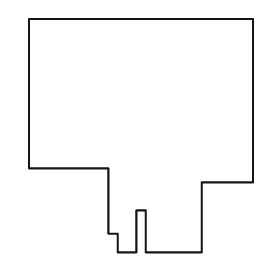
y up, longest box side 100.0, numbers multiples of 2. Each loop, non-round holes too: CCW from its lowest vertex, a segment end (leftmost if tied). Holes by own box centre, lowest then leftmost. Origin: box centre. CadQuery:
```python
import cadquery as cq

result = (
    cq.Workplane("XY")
    .moveTo(-10.0, -50.0)
    .lineTo(-2.0, -50.0)
    .lineTo(-2.0, -32.0)
    .lineTo(2.0, -32.0)
    .lineTo(2.0, -50.0)
    .lineTo(26.0, -50.0)
    .lineTo(26.0, -20.0)
    .lineTo(48.0, -20.0)
    .lineTo(48.0, 50.0)
    .lineTo(-48.0, 50.0)
    .lineTo(-48.0, -14.0)
    .lineTo(-14.0, -14.0)
    .lineTo(-14.0, -42.0)
    .lineTo(-10.0, -42.0)
    .close()
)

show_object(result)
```